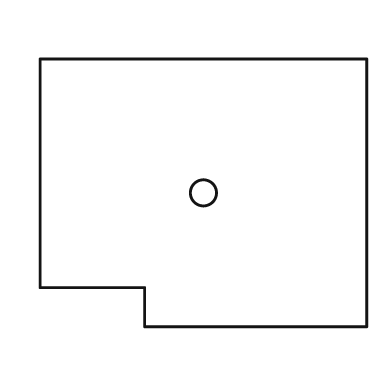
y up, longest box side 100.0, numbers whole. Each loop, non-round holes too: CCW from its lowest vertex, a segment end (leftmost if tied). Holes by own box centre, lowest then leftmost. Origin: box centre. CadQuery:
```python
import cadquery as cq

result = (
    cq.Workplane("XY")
    .moveTo(-18.0, -41.0)
    .lineTo(50.0, -41.0)
    .lineTo(50.0, 41.0)
    .lineTo(-50.0, 41.0)
    .lineTo(-50.0, -29.0)
    .lineTo(-18.0, -29.0)
    .close()
    .moveTo(0.0, 0.0)
    .circle(4.0)
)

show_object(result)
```